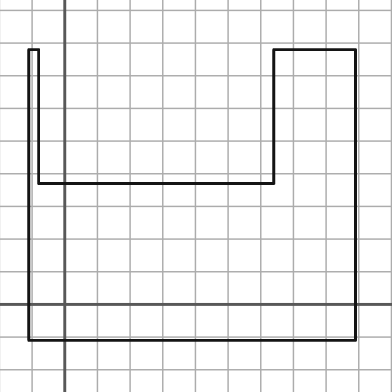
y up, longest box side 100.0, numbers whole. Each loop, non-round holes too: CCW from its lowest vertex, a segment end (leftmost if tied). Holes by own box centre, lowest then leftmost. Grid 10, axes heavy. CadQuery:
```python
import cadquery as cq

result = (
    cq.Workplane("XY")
    .moveTo(-11.0, -11.0)
    .lineTo(89.0, -11.0)
    .lineTo(89.0, 78.0)
    .lineTo(64.0, 78.0)
    .lineTo(64.0, 37.0)
    .lineTo(-8.0, 37.0)
    .lineTo(-8.0, 78.0)
    .lineTo(-11.0, 78.0)
    .close()
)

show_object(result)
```